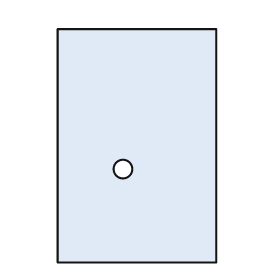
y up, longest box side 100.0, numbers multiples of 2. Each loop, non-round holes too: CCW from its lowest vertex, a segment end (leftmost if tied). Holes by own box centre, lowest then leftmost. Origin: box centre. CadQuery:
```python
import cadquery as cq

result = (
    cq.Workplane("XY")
    .moveTo(-34.0, -50.0)
    .lineTo(34.0, -50.0)
    .lineTo(34.0, 50.0)
    .lineTo(-34.0, 50.0)
    .close()
    .moveTo(-6.0, -10.0)
    .circle(4.0)
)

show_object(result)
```